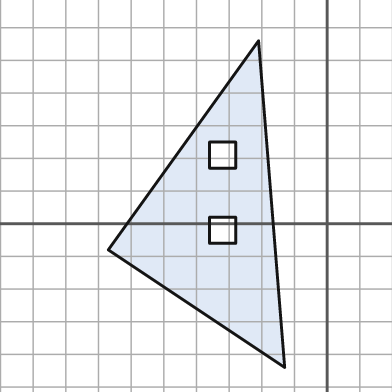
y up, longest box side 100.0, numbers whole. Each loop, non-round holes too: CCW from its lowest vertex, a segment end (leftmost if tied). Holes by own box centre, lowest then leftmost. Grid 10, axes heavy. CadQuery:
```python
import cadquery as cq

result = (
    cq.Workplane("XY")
    .moveTo(-13.0, -44.0)
    .lineTo(-21.0, 56.0)
    .lineTo(-67.0, -8.0)
    .close()
    .moveTo(-36.0, -6.0)
    .lineTo(-28.0, -6.0)
    .lineTo(-28.0, 2.0)
    .lineTo(-36.0, 2.0)
    .close()
    .moveTo(-36.0, 17.0)
    .lineTo(-28.0, 17.0)
    .lineTo(-28.0, 25.0)
    .lineTo(-36.0, 25.0)
    .close()
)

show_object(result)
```